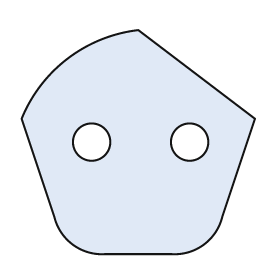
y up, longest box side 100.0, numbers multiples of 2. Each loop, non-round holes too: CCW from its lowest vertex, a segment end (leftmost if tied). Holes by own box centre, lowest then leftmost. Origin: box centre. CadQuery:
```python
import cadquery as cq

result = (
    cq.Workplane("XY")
    .moveTo(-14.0, -48.0)
    .lineTo(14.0, -48.0)
    .threePointArc((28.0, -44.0), (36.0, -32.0))
    .lineTo(50.0, 10.0)
    .lineTo(0.0, 48.0)
    .threePointArc((-30.0, 36.0), (-50.0, 10.0))
    .lineTo(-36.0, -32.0)
    .threePointArc((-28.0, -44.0), (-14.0, -48.0))
    .close()
    .moveTo(-20.0, 0.0)
    .circle(8.0)
    .moveTo(22.0, 0.0)
    .circle(8.0)
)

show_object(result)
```